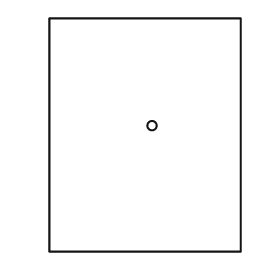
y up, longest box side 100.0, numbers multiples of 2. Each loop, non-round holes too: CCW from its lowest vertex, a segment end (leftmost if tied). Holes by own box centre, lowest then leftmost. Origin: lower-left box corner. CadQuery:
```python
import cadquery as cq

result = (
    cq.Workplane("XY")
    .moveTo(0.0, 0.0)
    .lineTo(82.0, 0.0)
    .lineTo(82.0, 100.0)
    .lineTo(0.0, 100.0)
    .close()
    .moveTo(44.0, 54.0)
    .circle(2.0)
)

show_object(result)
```